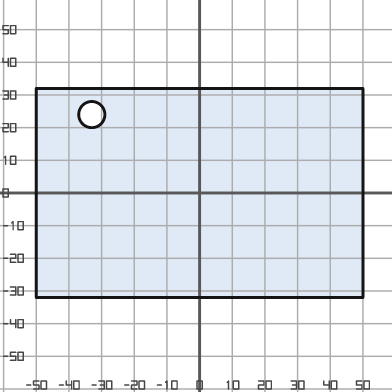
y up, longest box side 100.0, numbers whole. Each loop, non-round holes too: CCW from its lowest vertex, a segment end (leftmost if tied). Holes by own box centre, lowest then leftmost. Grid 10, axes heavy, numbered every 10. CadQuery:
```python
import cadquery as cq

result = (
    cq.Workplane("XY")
    .moveTo(-50.0, -32.0)
    .lineTo(50.0, -32.0)
    .lineTo(50.0, 32.0)
    .lineTo(-50.0, 32.0)
    .close()
    .moveTo(-33.0, 24.0)
    .circle(4.0)
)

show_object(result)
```